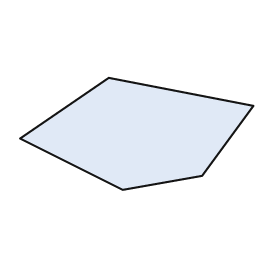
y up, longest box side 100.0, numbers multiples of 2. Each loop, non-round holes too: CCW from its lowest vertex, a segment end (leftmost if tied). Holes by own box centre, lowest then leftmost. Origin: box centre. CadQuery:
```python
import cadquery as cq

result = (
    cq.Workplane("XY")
    .moveTo(-6.0, -24.0)
    .lineTo(28.0, -18.0)
    .lineTo(50.0, 12.0)
    .lineTo(-12.0, 24.0)
    .lineTo(-50.0, -2.0)
    .close()
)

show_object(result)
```